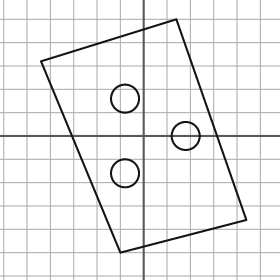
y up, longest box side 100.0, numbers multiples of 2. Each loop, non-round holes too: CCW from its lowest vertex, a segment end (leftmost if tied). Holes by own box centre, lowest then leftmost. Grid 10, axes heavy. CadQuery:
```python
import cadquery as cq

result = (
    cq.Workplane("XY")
    .moveTo(-10.0, -50.0)
    .lineTo(44.0, -36.0)
    .lineTo(14.0, 50.0)
    .lineTo(-44.0, 32.0)
    .close()
    .moveTo(-8.0, -16.0)
    .circle(6.0)
    .moveTo(18.0, 0.0)
    .circle(6.0)
    .moveTo(-8.0, 16.0)
    .circle(6.0)
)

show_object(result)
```